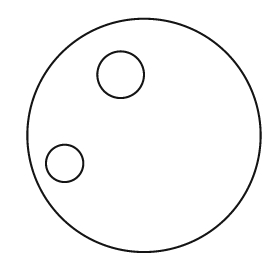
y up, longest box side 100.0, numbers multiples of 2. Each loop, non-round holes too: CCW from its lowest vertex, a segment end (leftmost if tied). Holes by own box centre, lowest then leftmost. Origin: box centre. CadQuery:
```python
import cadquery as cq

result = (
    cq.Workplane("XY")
    .moveTo(0.0, 0.0)
    .circle(50.0)
    .moveTo(-34.0, -12.0)
    .circle(8.0)
    .moveTo(-10.0, 26.0)
    .circle(10.0)
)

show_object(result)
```